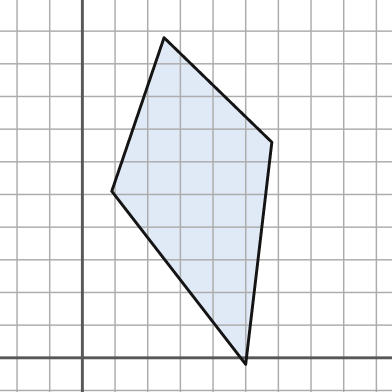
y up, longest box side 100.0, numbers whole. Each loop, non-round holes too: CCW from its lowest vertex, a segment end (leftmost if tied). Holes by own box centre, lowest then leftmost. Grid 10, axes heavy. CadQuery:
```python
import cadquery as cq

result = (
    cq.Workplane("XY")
    .moveTo(50.0, -2.0)
    .lineTo(58.0, 66.0)
    .lineTo(25.0, 98.0)
    .lineTo(9.0, 51.0)
    .close()
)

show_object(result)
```